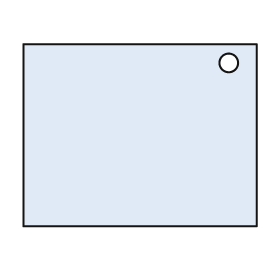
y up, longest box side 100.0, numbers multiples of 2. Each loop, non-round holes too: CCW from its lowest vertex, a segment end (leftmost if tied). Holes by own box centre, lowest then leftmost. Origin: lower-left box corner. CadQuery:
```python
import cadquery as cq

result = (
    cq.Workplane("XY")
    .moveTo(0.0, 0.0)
    .lineTo(100.0, 0.0)
    .lineTo(100.0, 78.0)
    .lineTo(0.0, 78.0)
    .close()
    .moveTo(88.0, 70.0)
    .circle(4.0)
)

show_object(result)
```